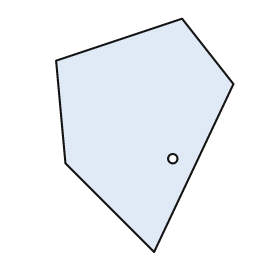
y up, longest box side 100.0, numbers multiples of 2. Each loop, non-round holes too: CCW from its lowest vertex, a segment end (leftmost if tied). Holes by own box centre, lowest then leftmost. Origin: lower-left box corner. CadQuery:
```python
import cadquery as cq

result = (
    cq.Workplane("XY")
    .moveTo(42.0, 0.0)
    .lineTo(76.0, 72.0)
    .lineTo(54.0, 100.0)
    .lineTo(0.0, 82.0)
    .lineTo(4.0, 38.0)
    .close()
    .moveTo(50.0, 40.0)
    .circle(2.0)
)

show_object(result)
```